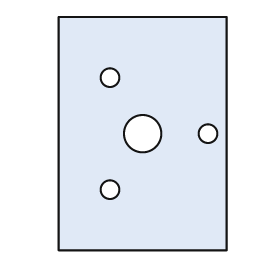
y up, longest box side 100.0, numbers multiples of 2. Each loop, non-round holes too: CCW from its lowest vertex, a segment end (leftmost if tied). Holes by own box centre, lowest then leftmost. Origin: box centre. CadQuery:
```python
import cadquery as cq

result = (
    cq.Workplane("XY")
    .moveTo(-36.0, -50.0)
    .lineTo(36.0, -50.0)
    .lineTo(36.0, 50.0)
    .lineTo(-36.0, 50.0)
    .close()
    .moveTo(-14.0, -24.0)
    .circle(4.0)
    .moveTo(0.0, 0.0)
    .circle(8.0)
    .moveTo(28.0, 0.0)
    .circle(4.0)
    .moveTo(-14.0, 24.0)
    .circle(4.0)
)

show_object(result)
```